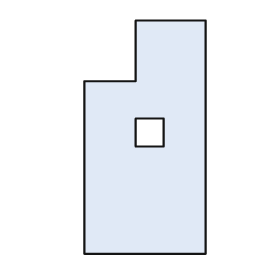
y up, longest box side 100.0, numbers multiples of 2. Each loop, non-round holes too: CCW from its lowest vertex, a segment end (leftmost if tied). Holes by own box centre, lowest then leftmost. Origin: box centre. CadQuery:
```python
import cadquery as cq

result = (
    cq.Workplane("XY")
    .moveTo(-26.0, -50.0)
    .lineTo(26.0, -50.0)
    .lineTo(26.0, 50.0)
    .lineTo(-4.0, 50.0)
    .lineTo(-4.0, 24.0)
    .lineTo(-26.0, 24.0)
    .close()
    .moveTo(-4.0, -4.0)
    .lineTo(8.0, -4.0)
    .lineTo(8.0, 8.0)
    .lineTo(-4.0, 8.0)
    .close()
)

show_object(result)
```